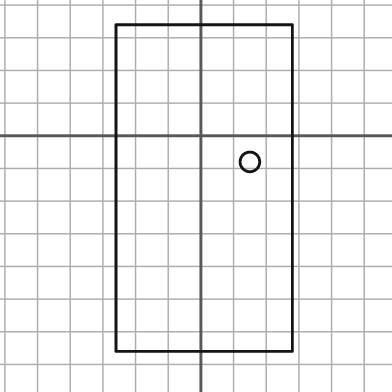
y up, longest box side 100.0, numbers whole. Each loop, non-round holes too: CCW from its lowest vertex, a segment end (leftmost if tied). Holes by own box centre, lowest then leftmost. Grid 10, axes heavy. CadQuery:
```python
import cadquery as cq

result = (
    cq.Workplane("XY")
    .moveTo(-26.0, -66.0)
    .lineTo(28.0, -66.0)
    .lineTo(28.0, 34.0)
    .lineTo(-26.0, 34.0)
    .close()
    .moveTo(15.0, -8.0)
    .circle(3.0)
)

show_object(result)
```